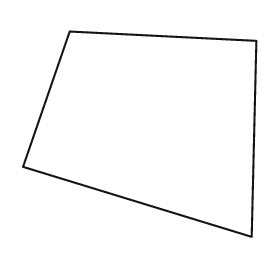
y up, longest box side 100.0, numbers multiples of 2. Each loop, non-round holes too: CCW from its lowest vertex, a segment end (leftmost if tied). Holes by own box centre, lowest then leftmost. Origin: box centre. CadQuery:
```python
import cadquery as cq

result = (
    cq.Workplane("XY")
    .moveTo(48.0, -44.0)
    .lineTo(50.0, 40.0)
    .lineTo(-30.0, 44.0)
    .lineTo(-50.0, -14.0)
    .close()
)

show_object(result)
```